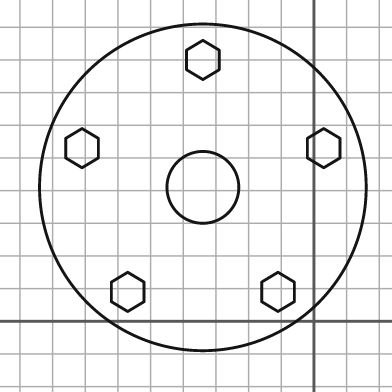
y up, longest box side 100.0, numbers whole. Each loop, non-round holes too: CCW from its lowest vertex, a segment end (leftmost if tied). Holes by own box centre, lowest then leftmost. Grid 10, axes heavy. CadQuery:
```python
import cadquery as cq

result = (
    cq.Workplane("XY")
    .moveTo(-34.0, 41.0)
    .circle(50.0)
    .moveTo(-57.0, 3.0)
    .lineTo(-52.0, 6.0)
    .lineTo(-52.0, 12.0)
    .lineTo(-57.0, 15.0)
    .lineTo(-62.0, 12.0)
    .lineTo(-62.0, 6.0)
    .close()
    .moveTo(-11.0, 3.0)
    .lineTo(-6.0, 6.0)
    .lineTo(-6.0, 12.0)
    .lineTo(-11.0, 15.0)
    .lineTo(-16.0, 12.0)
    .lineTo(-16.0, 6.0)
    .close()
    .moveTo(-34.0, 41.0)
    .circle(11.0)
    .moveTo(-71.0, 47.0)
    .lineTo(-66.0, 50.0)
    .lineTo(-66.0, 56.0)
    .lineTo(-71.0, 59.0)
    .lineTo(-76.0, 56.0)
    .lineTo(-76.0, 50.0)
    .close()
    .moveTo(3.0, 47.0)
    .lineTo(8.0, 50.0)
    .lineTo(8.0, 56.0)
    .lineTo(3.0, 59.0)
    .lineTo(-2.0, 56.0)
    .lineTo(-2.0, 50.0)
    .close()
    .moveTo(-34.0, 74.0)
    .lineTo(-29.0, 77.0)
    .lineTo(-29.0, 83.0)
    .lineTo(-34.0, 86.0)
    .lineTo(-39.0, 83.0)
    .lineTo(-39.0, 77.0)
    .close()
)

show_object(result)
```